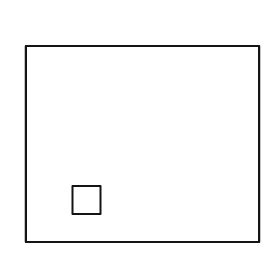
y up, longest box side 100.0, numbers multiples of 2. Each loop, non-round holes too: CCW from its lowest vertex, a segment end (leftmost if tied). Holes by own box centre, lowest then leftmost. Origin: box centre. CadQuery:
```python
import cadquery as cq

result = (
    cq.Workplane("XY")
    .moveTo(-50.0, -42.0)
    .lineTo(50.0, -42.0)
    .lineTo(50.0, 42.0)
    .lineTo(-50.0, 42.0)
    .close()
    .moveTo(-30.0, -30.0)
    .lineTo(-18.0, -30.0)
    .lineTo(-18.0, -18.0)
    .lineTo(-30.0, -18.0)
    .close()
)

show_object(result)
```